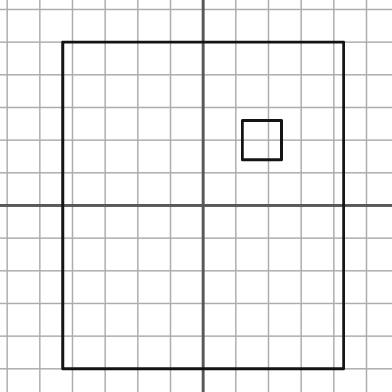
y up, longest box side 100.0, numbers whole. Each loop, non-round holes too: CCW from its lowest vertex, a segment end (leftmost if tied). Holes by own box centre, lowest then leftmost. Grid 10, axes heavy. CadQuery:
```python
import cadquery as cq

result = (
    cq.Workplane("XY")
    .moveTo(-43.0, -50.0)
    .lineTo(43.0, -50.0)
    .lineTo(43.0, 50.0)
    .lineTo(-43.0, 50.0)
    .close()
    .moveTo(12.0, 14.0)
    .lineTo(24.0, 14.0)
    .lineTo(24.0, 26.0)
    .lineTo(12.0, 26.0)
    .close()
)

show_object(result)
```